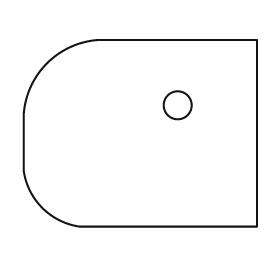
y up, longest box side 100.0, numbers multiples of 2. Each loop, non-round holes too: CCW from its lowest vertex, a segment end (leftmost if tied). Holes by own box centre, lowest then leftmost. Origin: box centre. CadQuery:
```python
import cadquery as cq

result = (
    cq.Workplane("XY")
    .moveTo(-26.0, -40.0)
    .lineTo(50.0, -40.0)
    .lineTo(50.0, 40.0)
    .lineTo(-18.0, 40.0)
    .threePointArc((-40.0, 30.0), (-50.0, 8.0))
    .lineTo(-50.0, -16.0)
    .threePointArc((-42.0, -32.0), (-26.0, -40.0))
    .close()
    .moveTo(16.0, 12.0)
    .circle(6.0)
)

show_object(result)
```